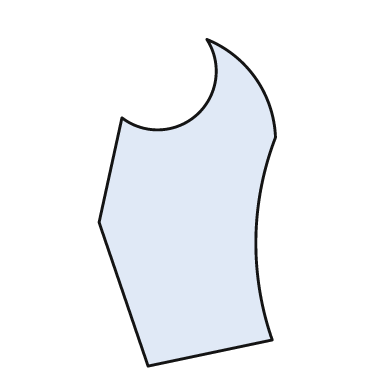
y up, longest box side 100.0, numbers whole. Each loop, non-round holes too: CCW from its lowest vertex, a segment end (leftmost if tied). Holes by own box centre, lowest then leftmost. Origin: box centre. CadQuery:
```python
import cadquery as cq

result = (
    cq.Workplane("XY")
    .moveTo(-12.0, -50.0)
    .lineTo(26.0, -42.0)
    .threePointArc((21.0, -11.0), (27.0, 20.0))
    .threePointArc((21.0, 38.0), (6.0, 50.0))
    .threePointArc((3.0, 27.0), (-20.0, 26.0))
    .lineTo(-27.0, -6.0)
    .close()
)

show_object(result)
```